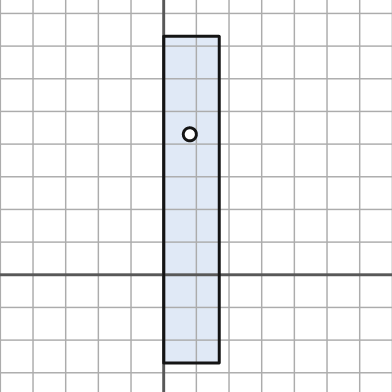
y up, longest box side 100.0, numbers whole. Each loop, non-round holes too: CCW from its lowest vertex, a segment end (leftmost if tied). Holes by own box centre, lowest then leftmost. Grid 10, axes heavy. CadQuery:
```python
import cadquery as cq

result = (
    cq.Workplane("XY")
    .moveTo(0.0, -27.0)
    .lineTo(17.0, -27.0)
    .lineTo(17.0, 73.0)
    .lineTo(0.0, 73.0)
    .close()
    .moveTo(8.0, 43.0)
    .circle(2.0)
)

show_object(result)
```